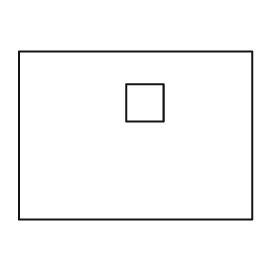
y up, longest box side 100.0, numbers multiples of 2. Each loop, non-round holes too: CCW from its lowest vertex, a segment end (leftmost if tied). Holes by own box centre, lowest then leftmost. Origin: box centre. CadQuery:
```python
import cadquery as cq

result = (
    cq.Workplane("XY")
    .moveTo(-50.0, -36.0)
    .lineTo(50.0, -36.0)
    .lineTo(50.0, 36.0)
    .lineTo(-50.0, 36.0)
    .close()
    .moveTo(-4.0, 6.0)
    .lineTo(12.0, 6.0)
    .lineTo(12.0, 22.0)
    .lineTo(-4.0, 22.0)
    .close()
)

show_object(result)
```